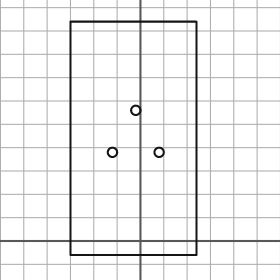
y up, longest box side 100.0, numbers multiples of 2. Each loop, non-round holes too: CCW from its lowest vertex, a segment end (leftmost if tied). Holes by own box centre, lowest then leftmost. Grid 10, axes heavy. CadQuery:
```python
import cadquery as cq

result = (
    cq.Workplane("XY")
    .moveTo(-30.0, -6.0)
    .lineTo(24.0, -6.0)
    .lineTo(24.0, 94.0)
    .lineTo(-30.0, 94.0)
    .close()
    .moveTo(-12.0, 38.0)
    .circle(2.0)
    .moveTo(8.0, 38.0)
    .circle(2.0)
    .moveTo(-2.0, 56.0)
    .circle(2.0)
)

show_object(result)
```